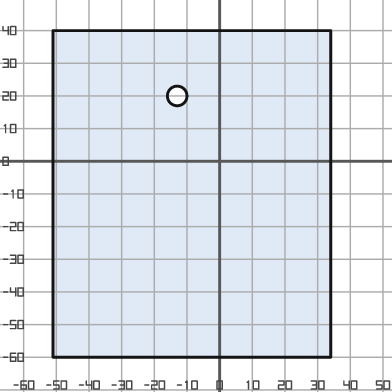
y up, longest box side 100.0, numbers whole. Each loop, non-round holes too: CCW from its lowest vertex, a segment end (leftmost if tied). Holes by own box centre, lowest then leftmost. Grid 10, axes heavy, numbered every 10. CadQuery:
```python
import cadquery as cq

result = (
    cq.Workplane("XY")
    .moveTo(-51.0, -60.0)
    .lineTo(34.0, -60.0)
    .lineTo(34.0, 40.0)
    .lineTo(-51.0, 40.0)
    .close()
    .moveTo(-13.0, 20.0)
    .circle(3.0)
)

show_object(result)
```